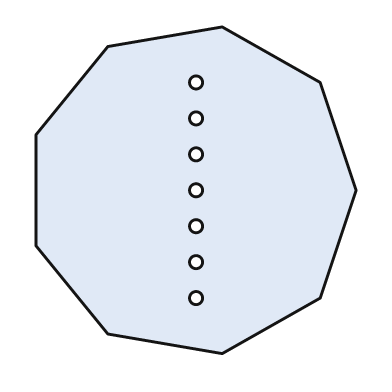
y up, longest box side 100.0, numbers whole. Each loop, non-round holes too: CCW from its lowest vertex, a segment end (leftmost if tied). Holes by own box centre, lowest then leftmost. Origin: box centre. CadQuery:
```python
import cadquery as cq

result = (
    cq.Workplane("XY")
    .moveTo(8.0, -50.0)
    .lineTo(38.0, -33.0)
    .lineTo(49.0, 0.0)
    .lineTo(38.0, 33.0)
    .lineTo(8.0, 50.0)
    .lineTo(-27.0, 44.0)
    .lineTo(-49.0, 17.0)
    .lineTo(-49.0, -17.0)
    .lineTo(-27.0, -44.0)
    .close()
    .moveTo(0.0, -33.0)
    .circle(2.0)
    .moveTo(0.0, -22.0)
    .circle(2.0)
    .moveTo(0.0, -11.0)
    .circle(2.0)
    .moveTo(0.0, 0.0)
    .circle(2.0)
    .moveTo(0.0, 11.0)
    .circle(2.0)
    .moveTo(0.0, 22.0)
    .circle(2.0)
    .moveTo(0.0, 33.0)
    .circle(2.0)
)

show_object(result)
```